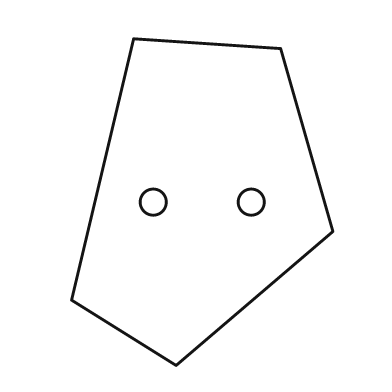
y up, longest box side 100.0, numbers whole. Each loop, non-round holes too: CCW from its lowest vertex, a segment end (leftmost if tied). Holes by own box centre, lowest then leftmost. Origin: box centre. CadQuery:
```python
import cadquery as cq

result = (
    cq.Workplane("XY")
    .moveTo(-8.0, -50.0)
    .lineTo(40.0, -9.0)
    .lineTo(24.0, 47.0)
    .lineTo(-21.0, 50.0)
    .lineTo(-40.0, -30.0)
    .close()
    .moveTo(-15.0, 0.0)
    .circle(4.0)
    .moveTo(15.0, 0.0)
    .circle(4.0)
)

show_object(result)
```